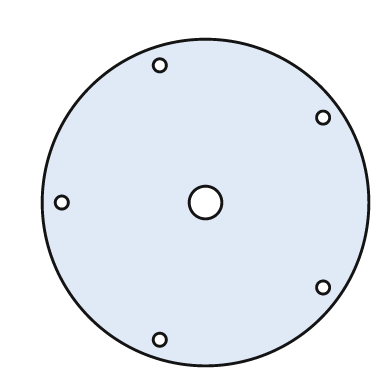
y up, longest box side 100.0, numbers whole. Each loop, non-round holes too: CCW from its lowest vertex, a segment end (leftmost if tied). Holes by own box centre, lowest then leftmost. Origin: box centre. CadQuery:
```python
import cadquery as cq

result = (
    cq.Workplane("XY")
    .moveTo(0.0, 0.0)
    .circle(50.0)
    .moveTo(-14.0, -42.0)
    .circle(2.0)
    .moveTo(36.0, -26.0)
    .circle(2.0)
    .moveTo(-44.0, 0.0)
    .circle(2.0)
    .moveTo(0.0, 0.0)
    .circle(5.0)
    .moveTo(36.0, 26.0)
    .circle(2.0)
    .moveTo(-14.0, 42.0)
    .circle(2.0)
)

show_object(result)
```